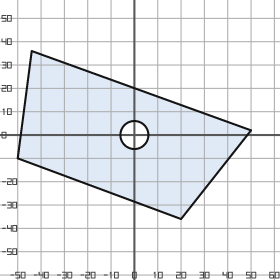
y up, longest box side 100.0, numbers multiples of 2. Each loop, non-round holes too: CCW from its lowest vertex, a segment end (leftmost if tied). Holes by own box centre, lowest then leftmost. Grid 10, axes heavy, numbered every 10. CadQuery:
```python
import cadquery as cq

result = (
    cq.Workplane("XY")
    .moveTo(20.0, -36.0)
    .lineTo(50.0, 2.0)
    .lineTo(-44.0, 36.0)
    .lineTo(-50.0, -10.0)
    .close()
    .moveTo(0.0, 0.0)
    .circle(6.0)
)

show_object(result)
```